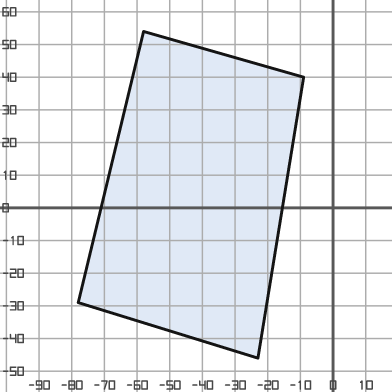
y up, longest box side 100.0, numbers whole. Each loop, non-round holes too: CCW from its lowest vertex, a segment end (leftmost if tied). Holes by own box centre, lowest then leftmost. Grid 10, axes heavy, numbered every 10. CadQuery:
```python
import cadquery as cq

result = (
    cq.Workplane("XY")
    .moveTo(-23.0, -46.0)
    .lineTo(-9.0, 40.0)
    .lineTo(-58.0, 54.0)
    .lineTo(-78.0, -29.0)
    .close()
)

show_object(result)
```